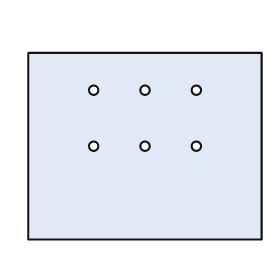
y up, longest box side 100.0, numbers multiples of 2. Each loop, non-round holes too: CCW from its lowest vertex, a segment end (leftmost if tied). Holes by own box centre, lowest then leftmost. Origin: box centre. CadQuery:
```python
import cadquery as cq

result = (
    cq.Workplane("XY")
    .moveTo(-50.0, -40.0)
    .lineTo(50.0, -40.0)
    .lineTo(50.0, 40.0)
    .lineTo(-50.0, 40.0)
    .close()
    .moveTo(-22.0, 0.0)
    .circle(2.0)
    .moveTo(0.0, 0.0)
    .circle(2.0)
    .moveTo(22.0, 0.0)
    .circle(2.0)
    .moveTo(-22.0, 24.0)
    .circle(2.0)
    .moveTo(0.0, 24.0)
    .circle(2.0)
    .moveTo(22.0, 24.0)
    .circle(2.0)
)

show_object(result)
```